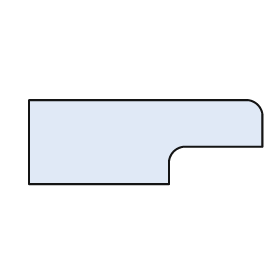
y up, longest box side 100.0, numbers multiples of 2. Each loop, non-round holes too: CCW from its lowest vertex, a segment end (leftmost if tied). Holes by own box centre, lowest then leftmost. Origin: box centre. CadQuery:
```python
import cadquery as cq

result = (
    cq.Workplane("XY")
    .moveTo(-50.0, -18.0)
    .lineTo(10.0, -18.0)
    .lineTo(10.0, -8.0)
    .threePointArc((12.0, -4.0), (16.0, -2.0))
    .lineTo(50.0, -2.0)
    .lineTo(50.0, 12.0)
    .threePointArc((48.0, 16.0), (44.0, 18.0))
    .lineTo(-50.0, 18.0)
    .close()
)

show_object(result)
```